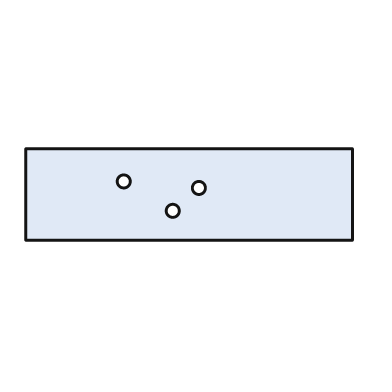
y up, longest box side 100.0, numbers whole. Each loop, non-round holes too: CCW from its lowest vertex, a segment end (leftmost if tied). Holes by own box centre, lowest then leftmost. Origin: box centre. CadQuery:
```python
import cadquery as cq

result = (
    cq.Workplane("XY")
    .moveTo(-50.0, -14.0)
    .lineTo(50.0, -14.0)
    .lineTo(50.0, 14.0)
    .lineTo(-50.0, 14.0)
    .close()
    .moveTo(-5.0, -5.0)
    .circle(2.0)
    .moveTo(3.0, 2.0)
    .circle(2.0)
    .moveTo(-20.0, 4.0)
    .circle(2.0)
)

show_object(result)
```